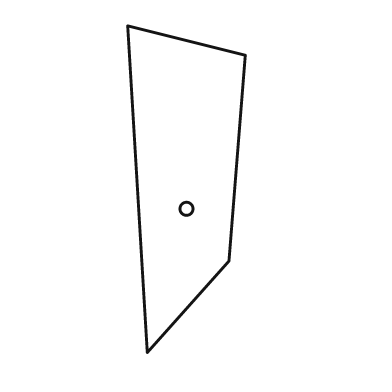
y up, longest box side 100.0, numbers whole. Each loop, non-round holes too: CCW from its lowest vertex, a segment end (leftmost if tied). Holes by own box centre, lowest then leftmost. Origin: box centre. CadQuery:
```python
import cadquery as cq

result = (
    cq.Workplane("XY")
    .moveTo(-12.0, -50.0)
    .lineTo(13.0, -22.0)
    .lineTo(18.0, 41.0)
    .lineTo(-18.0, 50.0)
    .close()
    .moveTo(0.0, -6.0)
    .circle(2.0)
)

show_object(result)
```